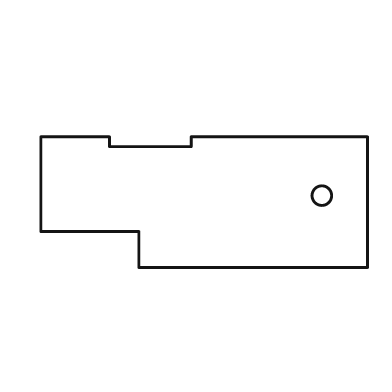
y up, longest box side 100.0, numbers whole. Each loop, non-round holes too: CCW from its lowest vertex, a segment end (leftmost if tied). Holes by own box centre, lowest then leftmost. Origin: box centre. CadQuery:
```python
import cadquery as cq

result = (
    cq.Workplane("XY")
    .moveTo(-20.0, -20.0)
    .lineTo(50.0, -20.0)
    .lineTo(50.0, 20.0)
    .lineTo(-4.0, 20.0)
    .lineTo(-4.0, 17.0)
    .lineTo(-29.0, 17.0)
    .lineTo(-29.0, 20.0)
    .lineTo(-50.0, 20.0)
    .lineTo(-50.0, -9.0)
    .lineTo(-20.0, -9.0)
    .close()
    .moveTo(36.0, 2.0)
    .circle(3.0)
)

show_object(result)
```